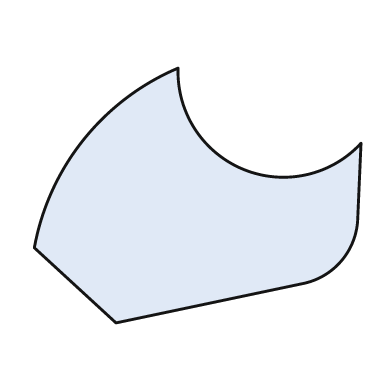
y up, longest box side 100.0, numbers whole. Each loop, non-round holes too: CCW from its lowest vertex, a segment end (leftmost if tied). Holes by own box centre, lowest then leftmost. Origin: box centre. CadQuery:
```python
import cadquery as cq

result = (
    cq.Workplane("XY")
    .moveTo(-25.0, -39.0)
    .lineTo(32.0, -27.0)
    .threePointArc((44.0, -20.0), (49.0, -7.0))
    .lineTo(50.0, 16.0)
    .threePointArc((14.0, 8.0), (-6.0, 39.0))
    .threePointArc((-35.0, 17.0), (-50.0, -16.0))
    .close()
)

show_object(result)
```